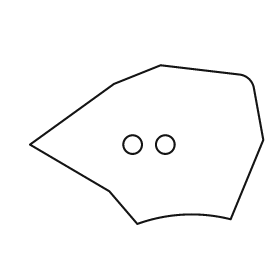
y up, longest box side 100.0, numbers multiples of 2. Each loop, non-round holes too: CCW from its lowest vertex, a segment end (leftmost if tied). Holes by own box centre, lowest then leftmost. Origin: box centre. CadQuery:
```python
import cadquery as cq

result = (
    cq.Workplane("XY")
    .moveTo(-4.0, -34.0)
    .threePointArc((16.0, -30.0), (36.0, -32.0))
    .lineTo(50.0, 2.0)
    .lineTo(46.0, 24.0)
    .threePointArc((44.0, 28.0), (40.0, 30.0))
    .lineTo(6.0, 34.0)
    .lineTo(-14.0, 26.0)
    .lineTo(-50.0, 0.0)
    .lineTo(-16.0, -20.0)
    .close()
    .moveTo(-6.0, 0.0)
    .circle(4.0)
    .moveTo(8.0, 0.0)
    .circle(4.0)
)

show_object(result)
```